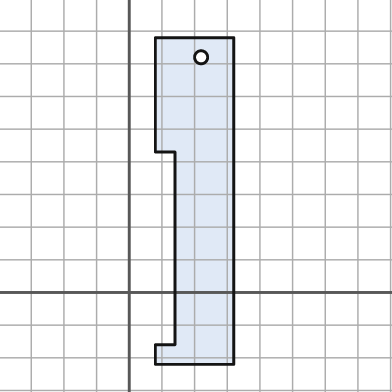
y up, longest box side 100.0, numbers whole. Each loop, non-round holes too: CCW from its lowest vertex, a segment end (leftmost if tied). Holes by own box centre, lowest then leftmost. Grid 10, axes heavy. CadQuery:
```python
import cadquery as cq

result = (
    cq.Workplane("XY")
    .moveTo(8.0, -22.0)
    .lineTo(32.0, -22.0)
    .lineTo(32.0, 78.0)
    .lineTo(8.0, 78.0)
    .lineTo(8.0, 43.0)
    .lineTo(14.0, 43.0)
    .lineTo(14.0, -16.0)
    .lineTo(8.0, -16.0)
    .close()
    .moveTo(22.0, 72.0)
    .circle(2.0)
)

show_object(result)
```